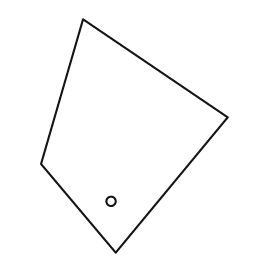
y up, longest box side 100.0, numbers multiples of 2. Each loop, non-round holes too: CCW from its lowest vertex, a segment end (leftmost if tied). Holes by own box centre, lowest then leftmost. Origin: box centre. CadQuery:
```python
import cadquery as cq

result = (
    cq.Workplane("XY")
    .moveTo(-8.0, -50.0)
    .lineTo(40.0, 8.0)
    .lineTo(-22.0, 50.0)
    .lineTo(-40.0, -12.0)
    .close()
    .moveTo(-10.0, -28.0)
    .circle(2.0)
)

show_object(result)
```